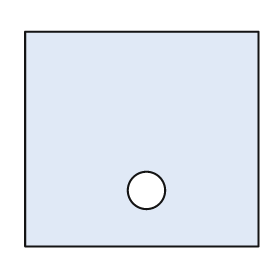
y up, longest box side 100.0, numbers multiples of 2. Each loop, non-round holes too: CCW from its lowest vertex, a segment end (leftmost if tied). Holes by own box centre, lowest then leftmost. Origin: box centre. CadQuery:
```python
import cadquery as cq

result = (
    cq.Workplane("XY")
    .moveTo(-50.0, -46.0)
    .lineTo(50.0, -46.0)
    .lineTo(50.0, 46.0)
    .lineTo(-50.0, 46.0)
    .close()
    .moveTo(2.0, -22.0)
    .circle(8.0)
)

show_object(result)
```